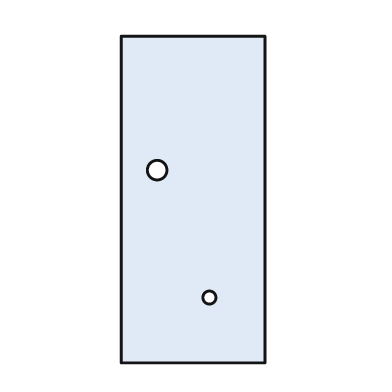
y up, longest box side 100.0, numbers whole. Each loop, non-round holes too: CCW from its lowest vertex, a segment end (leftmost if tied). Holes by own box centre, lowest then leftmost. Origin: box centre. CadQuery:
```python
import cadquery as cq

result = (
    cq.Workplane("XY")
    .moveTo(-22.0, -50.0)
    .lineTo(22.0, -50.0)
    .lineTo(22.0, 50.0)
    .lineTo(-22.0, 50.0)
    .close()
    .moveTo(5.0, -30.0)
    .circle(2.0)
    .moveTo(-11.0, 9.0)
    .circle(3.0)
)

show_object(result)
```